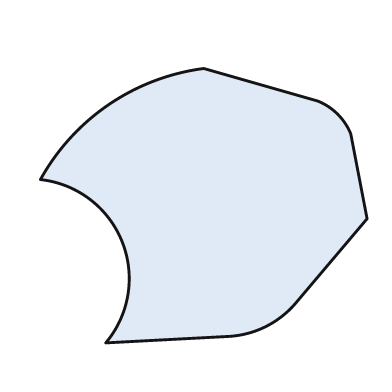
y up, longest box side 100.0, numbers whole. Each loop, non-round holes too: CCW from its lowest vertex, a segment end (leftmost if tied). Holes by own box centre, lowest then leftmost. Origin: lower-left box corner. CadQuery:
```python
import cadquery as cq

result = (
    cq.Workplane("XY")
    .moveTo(20.0, 0.0)
    .lineTo(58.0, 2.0)
    .threePointArc((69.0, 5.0), (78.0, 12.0))
    .lineTo(100.0, 38.0)
    .lineTo(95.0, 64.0)
    .threePointArc((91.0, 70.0), (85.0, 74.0))
    .lineTo(50.0, 84.0)
    .threePointArc((21.0, 73.0), (0.0, 50.0))
    .threePointArc((25.0, 31.0), (20.0, 0.0))
    .close()
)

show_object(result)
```